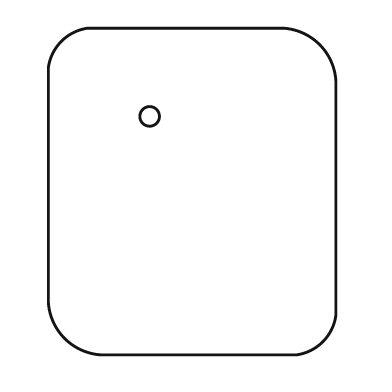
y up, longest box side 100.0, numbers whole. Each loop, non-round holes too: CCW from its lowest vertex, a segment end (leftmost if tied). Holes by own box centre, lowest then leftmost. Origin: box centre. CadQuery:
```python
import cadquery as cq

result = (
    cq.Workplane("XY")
    .moveTo(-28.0, -50.0)
    .lineTo(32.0, -50.0)
    .threePointArc((40.0, -46.0), (44.0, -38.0))
    .lineTo(44.0, 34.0)
    .threePointArc((39.0, 45.0), (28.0, 50.0))
    .lineTo(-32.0, 50.0)
    .threePointArc((-40.0, 46.0), (-44.0, 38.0))
    .lineTo(-44.0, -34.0)
    .threePointArc((-39.0, -45.0), (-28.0, -50.0))
    .close()
    .moveTo(-13.0, 23.0)
    .circle(3.0)
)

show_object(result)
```